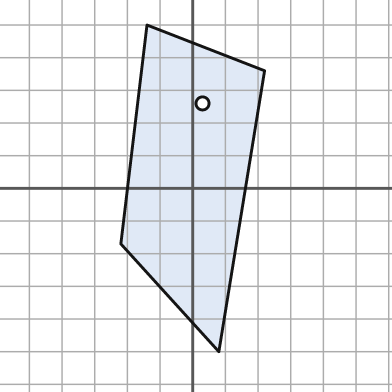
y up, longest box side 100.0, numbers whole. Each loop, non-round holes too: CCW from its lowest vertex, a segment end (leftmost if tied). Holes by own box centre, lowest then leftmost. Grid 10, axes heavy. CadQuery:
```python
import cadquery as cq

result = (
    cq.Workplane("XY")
    .moveTo(8.0, -50.0)
    .lineTo(22.0, 36.0)
    .lineTo(-14.0, 50.0)
    .lineTo(-22.0, -17.0)
    .close()
    .moveTo(3.0, 26.0)
    .circle(2.0)
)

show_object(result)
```